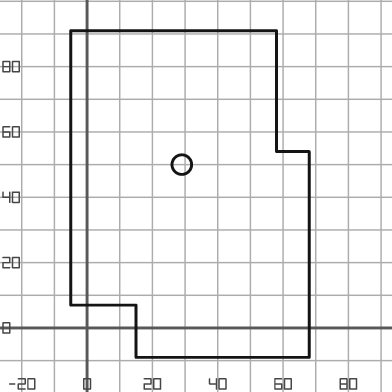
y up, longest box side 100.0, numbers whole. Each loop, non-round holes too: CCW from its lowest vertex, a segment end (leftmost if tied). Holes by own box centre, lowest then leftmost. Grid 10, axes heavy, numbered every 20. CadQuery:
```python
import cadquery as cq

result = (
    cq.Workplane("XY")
    .moveTo(15.0, -9.0)
    .lineTo(68.0, -9.0)
    .lineTo(68.0, 54.0)
    .lineTo(58.0, 54.0)
    .lineTo(58.0, 91.0)
    .lineTo(-5.0, 91.0)
    .lineTo(-5.0, 7.0)
    .lineTo(15.0, 7.0)
    .close()
    .moveTo(29.0, 50.0)
    .circle(3.0)
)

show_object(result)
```